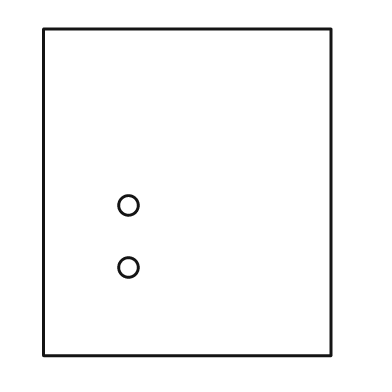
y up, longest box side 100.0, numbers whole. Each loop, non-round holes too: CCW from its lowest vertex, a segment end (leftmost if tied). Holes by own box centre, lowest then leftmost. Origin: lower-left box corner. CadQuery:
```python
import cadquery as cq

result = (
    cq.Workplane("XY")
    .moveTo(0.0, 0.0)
    .lineTo(88.0, 0.0)
    .lineTo(88.0, 100.0)
    .lineTo(0.0, 100.0)
    .close()
    .moveTo(26.0, 27.0)
    .circle(3.0)
    .moveTo(26.0, 46.0)
    .circle(3.0)
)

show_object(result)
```